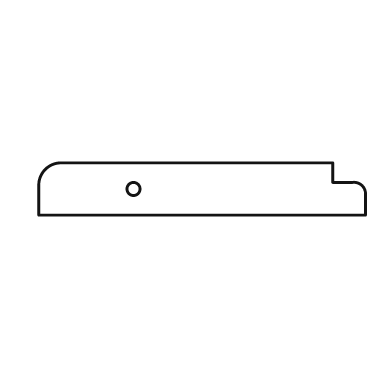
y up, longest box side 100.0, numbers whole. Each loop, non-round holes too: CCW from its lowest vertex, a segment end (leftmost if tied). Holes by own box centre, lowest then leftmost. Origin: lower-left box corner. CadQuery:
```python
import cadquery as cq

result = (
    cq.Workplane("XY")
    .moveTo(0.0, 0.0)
    .lineTo(100.0, 0.0)
    .lineTo(100.0, 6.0)
    .threePointArc((99.0, 9.0), (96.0, 10.0))
    .lineTo(90.0, 10.0)
    .lineTo(90.0, 16.0)
    .lineTo(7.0, 16.0)
    .threePointArc((2.0, 14.0), (0.0, 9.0))
    .close()
    .moveTo(29.0, 8.0)
    .circle(2.0)
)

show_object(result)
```